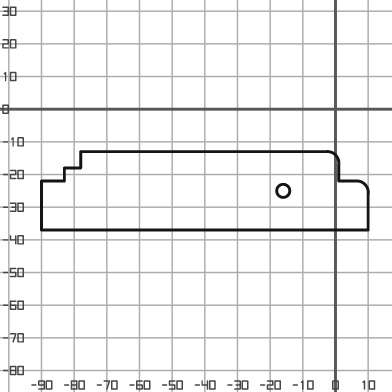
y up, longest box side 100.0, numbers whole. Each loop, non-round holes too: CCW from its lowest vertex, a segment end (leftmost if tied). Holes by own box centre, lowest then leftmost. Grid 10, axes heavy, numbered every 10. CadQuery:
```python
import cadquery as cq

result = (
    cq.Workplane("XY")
    .moveTo(-90.0, -37.0)
    .lineTo(10.0, -37.0)
    .lineTo(10.0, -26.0)
    .threePointArc((9.0, -23.0), (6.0, -22.0))
    .lineTo(1.0, -22.0)
    .lineTo(1.0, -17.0)
    .threePointArc((0.0, -14.0), (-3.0, -13.0))
    .lineTo(-78.0, -13.0)
    .lineTo(-78.0, -18.0)
    .lineTo(-83.0, -18.0)
    .lineTo(-83.0, -22.0)
    .lineTo(-90.0, -22.0)
    .close()
    .moveTo(-16.0, -25.0)
    .circle(2.0)
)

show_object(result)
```